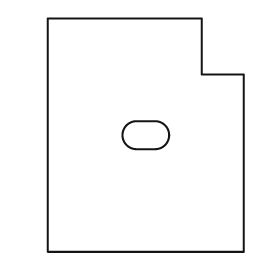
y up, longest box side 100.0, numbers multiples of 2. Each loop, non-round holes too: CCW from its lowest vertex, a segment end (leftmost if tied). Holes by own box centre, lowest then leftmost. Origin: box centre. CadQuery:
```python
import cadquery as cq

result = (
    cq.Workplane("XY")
    .moveTo(-42.0, -50.0)
    .lineTo(42.0, -50.0)
    .lineTo(42.0, 26.0)
    .lineTo(24.0, 26.0)
    .lineTo(24.0, 50.0)
    .lineTo(-42.0, 50.0)
    .close()
    .moveTo(-4.0, -6.0)
    .lineTo(4.0, -6.0)
    .threePointArc((10.0, 0.0), (4.0, 6.0))
    .lineTo(-4.0, 6.0)
    .threePointArc((-10.0, 0.0), (-4.0, -6.0))
    .close()
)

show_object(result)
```